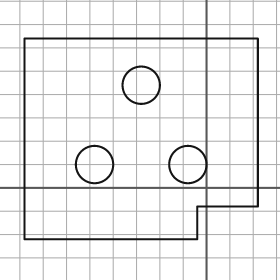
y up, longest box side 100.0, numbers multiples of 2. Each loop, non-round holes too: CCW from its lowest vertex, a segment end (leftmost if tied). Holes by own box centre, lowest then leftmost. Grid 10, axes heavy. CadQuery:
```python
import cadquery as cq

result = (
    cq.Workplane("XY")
    .moveTo(-78.0, -22.0)
    .lineTo(-4.0, -22.0)
    .lineTo(-4.0, -8.0)
    .lineTo(22.0, -8.0)
    .lineTo(22.0, 64.0)
    .lineTo(-78.0, 64.0)
    .close()
    .moveTo(-48.0, 10.0)
    .circle(8.0)
    .moveTo(-8.0, 10.0)
    .circle(8.0)
    .moveTo(-28.0, 44.0)
    .circle(8.0)
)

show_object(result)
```